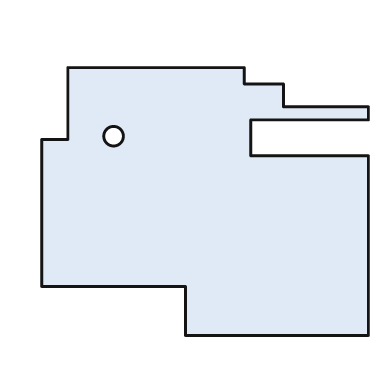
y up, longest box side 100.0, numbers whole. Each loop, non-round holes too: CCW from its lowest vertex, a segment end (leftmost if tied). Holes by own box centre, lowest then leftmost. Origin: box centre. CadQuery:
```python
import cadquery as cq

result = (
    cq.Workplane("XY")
    .moveTo(-6.0, -41.0)
    .lineTo(50.0, -41.0)
    .lineTo(50.0, 14.0)
    .lineTo(14.0, 14.0)
    .lineTo(14.0, 25.0)
    .lineTo(50.0, 25.0)
    .lineTo(50.0, 29.0)
    .lineTo(24.0, 29.0)
    .lineTo(24.0, 36.0)
    .lineTo(12.0, 36.0)
    .lineTo(12.0, 41.0)
    .lineTo(-42.0, 41.0)
    .lineTo(-42.0, 19.0)
    .lineTo(-50.0, 19.0)
    .lineTo(-50.0, -26.0)
    .lineTo(-6.0, -26.0)
    .close()
    .moveTo(-28.0, 20.0)
    .circle(3.0)
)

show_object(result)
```